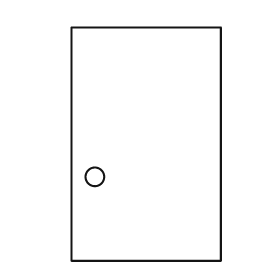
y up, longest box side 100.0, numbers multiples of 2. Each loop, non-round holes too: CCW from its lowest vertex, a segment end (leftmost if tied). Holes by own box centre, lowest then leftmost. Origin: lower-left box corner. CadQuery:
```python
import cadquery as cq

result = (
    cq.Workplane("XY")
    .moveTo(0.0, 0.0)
    .lineTo(64.0, 0.0)
    .lineTo(64.0, 100.0)
    .lineTo(0.0, 100.0)
    .close()
    .moveTo(10.0, 36.0)
    .circle(4.0)
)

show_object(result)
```